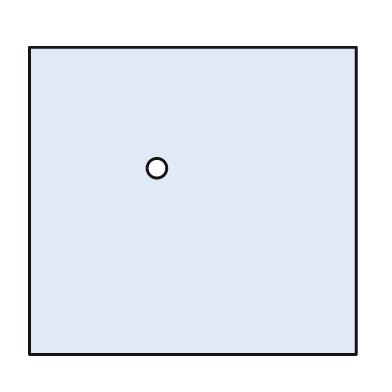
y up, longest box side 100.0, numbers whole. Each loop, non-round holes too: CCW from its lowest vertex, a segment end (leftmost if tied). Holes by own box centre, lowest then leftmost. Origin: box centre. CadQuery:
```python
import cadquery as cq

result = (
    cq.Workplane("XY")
    .moveTo(-50.0, -47.0)
    .lineTo(50.0, -47.0)
    .lineTo(50.0, 47.0)
    .lineTo(-50.0, 47.0)
    .close()
    .moveTo(-11.0, 10.0)
    .circle(3.0)
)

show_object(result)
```